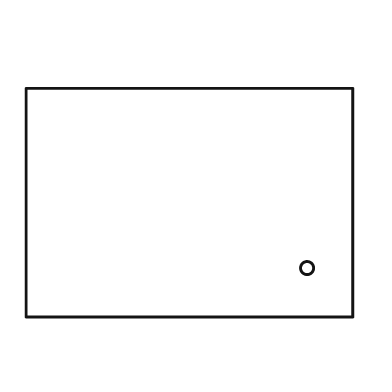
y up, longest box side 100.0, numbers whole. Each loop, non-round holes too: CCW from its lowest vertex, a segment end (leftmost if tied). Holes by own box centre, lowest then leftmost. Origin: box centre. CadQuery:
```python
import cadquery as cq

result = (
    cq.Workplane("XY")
    .moveTo(-50.0, -35.0)
    .lineTo(50.0, -35.0)
    .lineTo(50.0, 35.0)
    .lineTo(-50.0, 35.0)
    .close()
    .moveTo(36.0, -20.0)
    .circle(2.0)
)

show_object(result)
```